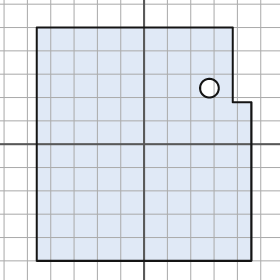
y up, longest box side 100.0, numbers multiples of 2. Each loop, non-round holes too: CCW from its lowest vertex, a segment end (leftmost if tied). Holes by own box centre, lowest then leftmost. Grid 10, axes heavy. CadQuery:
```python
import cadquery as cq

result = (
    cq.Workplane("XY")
    .moveTo(-46.0, -50.0)
    .lineTo(46.0, -50.0)
    .lineTo(46.0, 18.0)
    .lineTo(38.0, 18.0)
    .lineTo(38.0, 50.0)
    .lineTo(-46.0, 50.0)
    .close()
    .moveTo(28.0, 24.0)
    .circle(4.0)
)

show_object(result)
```